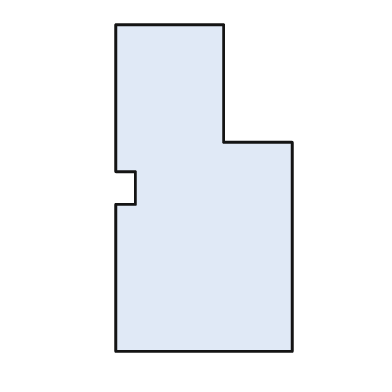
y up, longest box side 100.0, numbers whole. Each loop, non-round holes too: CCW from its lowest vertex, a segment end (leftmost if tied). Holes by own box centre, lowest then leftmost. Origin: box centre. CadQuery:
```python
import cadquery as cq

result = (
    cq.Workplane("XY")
    .moveTo(-27.0, -50.0)
    .lineTo(27.0, -50.0)
    .lineTo(27.0, 14.0)
    .lineTo(6.0, 14.0)
    .lineTo(6.0, 50.0)
    .lineTo(-27.0, 50.0)
    .lineTo(-27.0, 5.0)
    .lineTo(-21.0, 5.0)
    .lineTo(-21.0, -5.0)
    .lineTo(-27.0, -5.0)
    .close()
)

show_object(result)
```